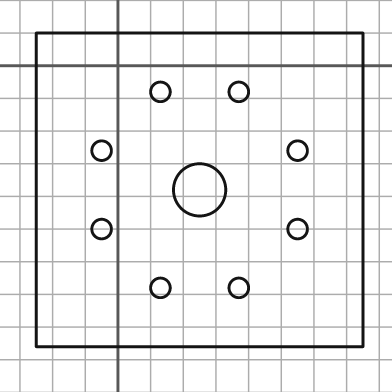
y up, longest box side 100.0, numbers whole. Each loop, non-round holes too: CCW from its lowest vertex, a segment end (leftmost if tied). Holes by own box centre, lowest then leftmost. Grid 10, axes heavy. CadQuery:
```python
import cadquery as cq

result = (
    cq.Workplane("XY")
    .moveTo(-25.0, -86.0)
    .lineTo(75.0, -86.0)
    .lineTo(75.0, 10.0)
    .lineTo(-25.0, 10.0)
    .close()
    .moveTo(13.0, -68.0)
    .circle(3.0)
    .moveTo(37.0, -68.0)
    .circle(3.0)
    .moveTo(-5.0, -50.0)
    .circle(3.0)
    .moveTo(55.0, -50.0)
    .circle(3.0)
    .moveTo(25.0, -38.0)
    .circle(8.0)
    .moveTo(-5.0, -26.0)
    .circle(3.0)
    .moveTo(55.0, -26.0)
    .circle(3.0)
    .moveTo(13.0, -8.0)
    .circle(3.0)
    .moveTo(37.0, -8.0)
    .circle(3.0)
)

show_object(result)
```